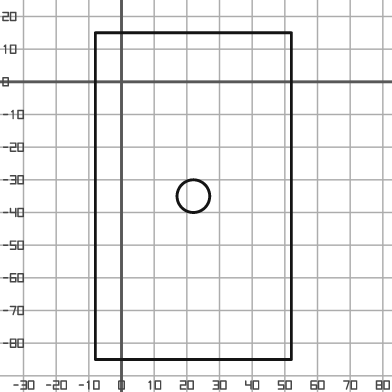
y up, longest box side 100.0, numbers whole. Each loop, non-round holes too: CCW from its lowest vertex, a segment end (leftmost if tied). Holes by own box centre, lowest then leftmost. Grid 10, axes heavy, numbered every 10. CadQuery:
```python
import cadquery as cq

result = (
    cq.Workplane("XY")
    .moveTo(-8.0, -85.0)
    .lineTo(52.0, -85.0)
    .lineTo(52.0, 15.0)
    .lineTo(-8.0, 15.0)
    .close()
    .moveTo(22.0, -35.0)
    .circle(5.0)
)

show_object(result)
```